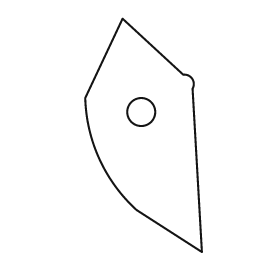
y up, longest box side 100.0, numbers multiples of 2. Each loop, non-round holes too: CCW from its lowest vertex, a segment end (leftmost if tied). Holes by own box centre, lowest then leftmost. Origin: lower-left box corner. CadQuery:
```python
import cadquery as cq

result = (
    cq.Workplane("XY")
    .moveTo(50.0, 0.0)
    .lineTo(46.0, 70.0)
    .threePointArc((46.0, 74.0), (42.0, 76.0))
    .lineTo(16.0, 100.0)
    .lineTo(0.0, 66.0)
    .threePointArc((6.0, 40.0), (22.0, 18.0))
    .close()
    .moveTo(24.0, 60.0)
    .circle(6.0)
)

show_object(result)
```